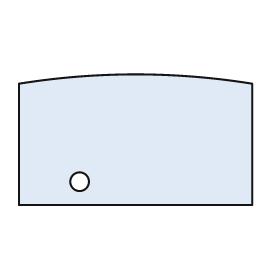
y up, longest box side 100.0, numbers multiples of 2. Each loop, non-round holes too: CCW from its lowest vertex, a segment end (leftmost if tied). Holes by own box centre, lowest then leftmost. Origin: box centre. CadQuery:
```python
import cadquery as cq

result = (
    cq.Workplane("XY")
    .moveTo(-50.0, -28.0)
    .lineTo(50.0, -28.0)
    .lineTo(50.0, 24.0)
    .threePointArc((0.0, 28.0), (-50.0, 24.0))
    .close()
    .moveTo(-24.0, -18.0)
    .circle(4.0)
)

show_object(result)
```